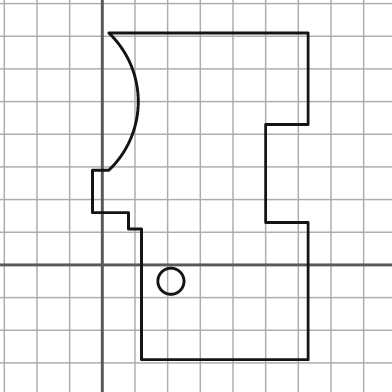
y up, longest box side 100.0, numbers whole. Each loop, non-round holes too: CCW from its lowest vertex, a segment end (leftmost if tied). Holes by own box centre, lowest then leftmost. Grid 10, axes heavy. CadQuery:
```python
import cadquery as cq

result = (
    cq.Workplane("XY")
    .moveTo(12.0, -29.0)
    .lineTo(63.0, -29.0)
    .lineTo(63.0, 13.0)
    .lineTo(50.0, 13.0)
    .lineTo(50.0, 43.0)
    .lineTo(63.0, 43.0)
    .lineTo(63.0, 71.0)
    .lineTo(2.0, 71.0)
    .threePointArc((11.0, 50.0), (2.0, 29.0))
    .lineTo(-3.0, 29.0)
    .lineTo(-3.0, 16.0)
    .lineTo(8.0, 16.0)
    .lineTo(8.0, 11.0)
    .lineTo(12.0, 11.0)
    .close()
    .moveTo(21.0, -5.0)
    .circle(4.0)
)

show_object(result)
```